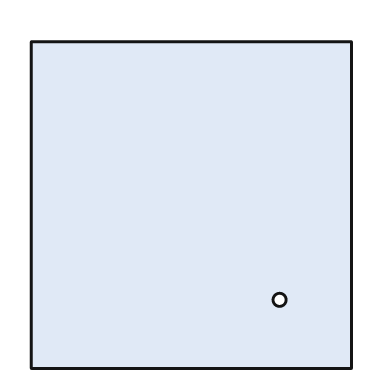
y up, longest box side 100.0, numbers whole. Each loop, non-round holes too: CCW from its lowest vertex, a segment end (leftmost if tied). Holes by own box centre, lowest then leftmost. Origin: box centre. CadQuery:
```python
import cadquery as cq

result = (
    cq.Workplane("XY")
    .moveTo(-49.0, -50.0)
    .lineTo(49.0, -50.0)
    .lineTo(49.0, 50.0)
    .lineTo(-49.0, 50.0)
    .close()
    .moveTo(27.0, -29.0)
    .circle(2.0)
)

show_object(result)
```